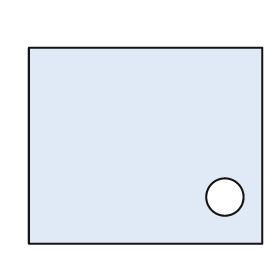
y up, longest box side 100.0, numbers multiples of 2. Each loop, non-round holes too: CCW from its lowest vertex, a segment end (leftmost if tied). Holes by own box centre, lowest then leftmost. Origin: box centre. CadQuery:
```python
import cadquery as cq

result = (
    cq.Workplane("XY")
    .moveTo(-50.0, -42.0)
    .lineTo(50.0, -42.0)
    .lineTo(50.0, 42.0)
    .lineTo(-50.0, 42.0)
    .close()
    .moveTo(34.0, -22.0)
    .circle(8.0)
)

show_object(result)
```